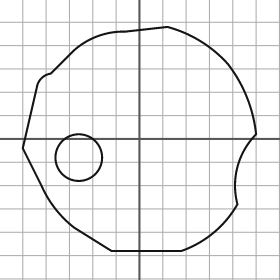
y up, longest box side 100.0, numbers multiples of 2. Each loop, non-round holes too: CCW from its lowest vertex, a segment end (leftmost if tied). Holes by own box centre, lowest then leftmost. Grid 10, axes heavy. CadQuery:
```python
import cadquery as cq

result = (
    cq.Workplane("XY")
    .moveTo(-12.0, -48.0)
    .lineTo(18.0, -48.0)
    .threePointArc((32.0, -40.0), (42.0, -28.0))
    .threePointArc((42.0, -12.0), (50.0, 2.0))
    .threePointArc((46.0, 18.0), (38.0, 32.0))
    .threePointArc((26.0, 42.0), (12.0, 48.0))
    .lineTo(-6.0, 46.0)
    .threePointArc((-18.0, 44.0), (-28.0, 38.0))
    .lineTo(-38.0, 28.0)
    .threePointArc((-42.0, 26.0), (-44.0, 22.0))
    .lineTo(-50.0, -4.0)
    .lineTo(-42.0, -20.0)
    .threePointArc((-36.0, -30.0), (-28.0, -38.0))
    .close()
    .moveTo(-26.0, -8.0)
    .circle(10.0)
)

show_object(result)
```